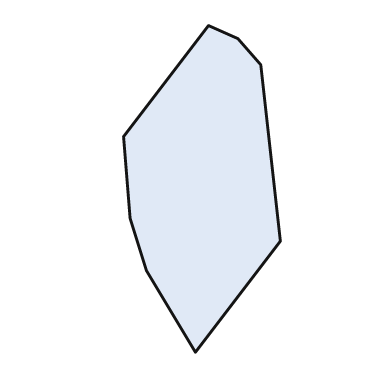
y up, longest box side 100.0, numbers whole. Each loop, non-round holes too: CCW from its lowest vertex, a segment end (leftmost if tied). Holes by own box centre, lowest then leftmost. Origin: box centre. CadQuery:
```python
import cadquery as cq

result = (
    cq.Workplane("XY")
    .moveTo(-2.0, -50.0)
    .lineTo(24.0, -16.0)
    .lineTo(18.0, 38.0)
    .lineTo(11.0, 46.0)
    .lineTo(2.0, 50.0)
    .lineTo(-24.0, 16.0)
    .lineTo(-22.0, -9.0)
    .lineTo(-17.0, -25.0)
    .close()
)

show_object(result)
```